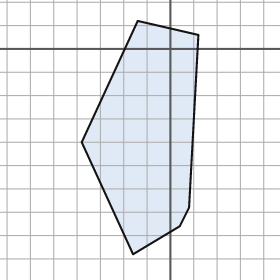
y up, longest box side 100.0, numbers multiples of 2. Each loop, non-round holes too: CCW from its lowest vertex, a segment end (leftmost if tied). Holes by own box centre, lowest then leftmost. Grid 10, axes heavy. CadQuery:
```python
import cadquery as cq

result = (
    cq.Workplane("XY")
    .moveTo(-16.0, -88.0)
    .lineTo(4.0, -76.0)
    .lineTo(8.0, -68.0)
    .lineTo(12.0, 6.0)
    .lineTo(-14.0, 12.0)
    .lineTo(-38.0, -40.0)
    .close()
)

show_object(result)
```